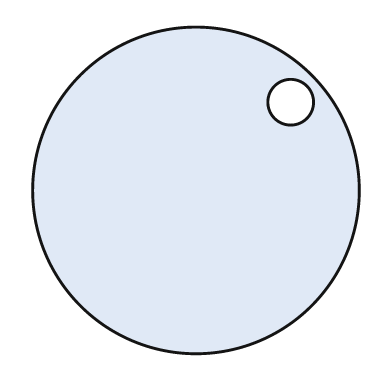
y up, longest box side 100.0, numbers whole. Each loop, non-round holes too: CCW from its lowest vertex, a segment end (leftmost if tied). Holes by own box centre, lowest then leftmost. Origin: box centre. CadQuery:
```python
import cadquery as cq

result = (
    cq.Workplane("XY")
    .moveTo(0.0, 0.0)
    .circle(50.0)
    .moveTo(29.0, 27.0)
    .circle(7.0)
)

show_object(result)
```